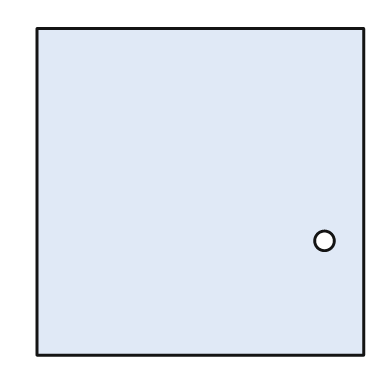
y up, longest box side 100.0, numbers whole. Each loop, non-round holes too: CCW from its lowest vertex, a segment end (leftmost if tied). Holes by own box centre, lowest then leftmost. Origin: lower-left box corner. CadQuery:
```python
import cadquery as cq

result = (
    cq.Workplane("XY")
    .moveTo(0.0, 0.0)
    .lineTo(100.0, 0.0)
    .lineTo(100.0, 100.0)
    .lineTo(0.0, 100.0)
    .close()
    .moveTo(88.0, 35.0)
    .circle(3.0)
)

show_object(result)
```